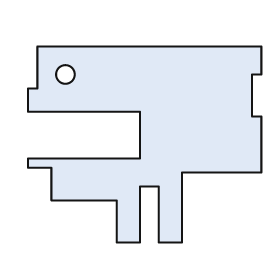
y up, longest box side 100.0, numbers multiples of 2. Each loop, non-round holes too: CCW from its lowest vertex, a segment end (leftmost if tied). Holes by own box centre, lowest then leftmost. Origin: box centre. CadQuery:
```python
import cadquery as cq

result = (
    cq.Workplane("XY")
    .moveTo(-12.0, -42.0)
    .lineTo(-2.0, -42.0)
    .lineTo(-2.0, -18.0)
    .lineTo(6.0, -18.0)
    .lineTo(6.0, -42.0)
    .lineTo(16.0, -42.0)
    .lineTo(16.0, -12.0)
    .lineTo(50.0, -12.0)
    .lineTo(50.0, 12.0)
    .lineTo(46.0, 12.0)
    .lineTo(46.0, 30.0)
    .lineTo(50.0, 30.0)
    .lineTo(50.0, 42.0)
    .lineTo(-46.0, 42.0)
    .lineTo(-46.0, 24.0)
    .lineTo(-50.0, 24.0)
    .lineTo(-50.0, 14.0)
    .lineTo(-2.0, 14.0)
    .lineTo(-2.0, -6.0)
    .lineTo(-50.0, -6.0)
    .lineTo(-50.0, -10.0)
    .lineTo(-40.0, -10.0)
    .lineTo(-40.0, -24.0)
    .lineTo(-12.0, -24.0)
    .close()
    .moveTo(-34.0, 30.0)
    .circle(4.0)
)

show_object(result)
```